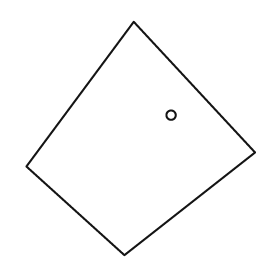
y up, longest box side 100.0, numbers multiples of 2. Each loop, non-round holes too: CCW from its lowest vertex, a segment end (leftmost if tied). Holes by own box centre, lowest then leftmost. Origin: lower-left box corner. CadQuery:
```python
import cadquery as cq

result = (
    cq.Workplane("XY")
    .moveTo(42.0, 0.0)
    .lineTo(98.0, 44.0)
    .lineTo(46.0, 100.0)
    .lineTo(0.0, 38.0)
    .close()
    .moveTo(62.0, 60.0)
    .circle(2.0)
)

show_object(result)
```